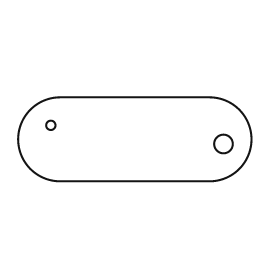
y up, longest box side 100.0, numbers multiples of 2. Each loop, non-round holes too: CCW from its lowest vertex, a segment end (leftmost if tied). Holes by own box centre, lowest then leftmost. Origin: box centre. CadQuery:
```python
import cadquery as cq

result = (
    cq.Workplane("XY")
    .moveTo(-32.0, -18.0)
    .lineTo(32.0, -18.0)
    .threePointArc((50.0, 0.0), (32.0, 18.0))
    .lineTo(-32.0, 18.0)
    .threePointArc((-50.0, 0.0), (-32.0, -18.0))
    .close()
    .moveTo(38.0, -2.0)
    .circle(4.0)
    .moveTo(-36.0, 6.0)
    .circle(2.0)
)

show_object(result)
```